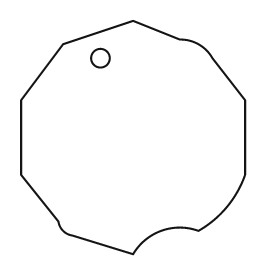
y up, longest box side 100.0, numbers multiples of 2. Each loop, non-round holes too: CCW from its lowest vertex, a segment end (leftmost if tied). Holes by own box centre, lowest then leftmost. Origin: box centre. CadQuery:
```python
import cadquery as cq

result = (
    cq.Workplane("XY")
    .moveTo(0.0, -50.0)
    .threePointArc((12.0, -40.0), (28.0, -40.0))
    .threePointArc((40.0, -30.0), (48.0, -16.0))
    .lineTo(48.0, 16.0)
    .lineTo(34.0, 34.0)
    .threePointArc((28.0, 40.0), (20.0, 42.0))
    .lineTo(0.0, 50.0)
    .lineTo(-30.0, 40.0)
    .lineTo(-48.0, 16.0)
    .lineTo(-48.0, -16.0)
    .lineTo(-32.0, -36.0)
    .threePointArc((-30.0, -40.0), (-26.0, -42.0))
    .close()
    .moveTo(-14.0, 34.0)
    .circle(4.0)
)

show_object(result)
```